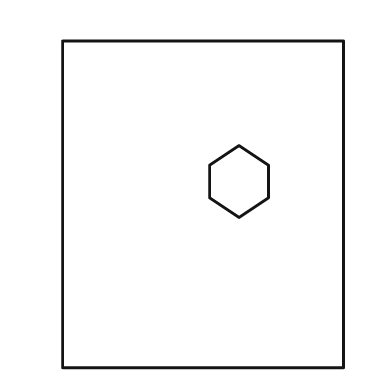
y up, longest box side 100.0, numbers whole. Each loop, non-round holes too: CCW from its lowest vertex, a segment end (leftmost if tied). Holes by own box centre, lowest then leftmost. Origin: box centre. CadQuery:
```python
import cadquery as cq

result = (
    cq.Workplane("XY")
    .moveTo(-43.0, -50.0)
    .lineTo(43.0, -50.0)
    .lineTo(43.0, 50.0)
    .lineTo(-43.0, 50.0)
    .close()
    .moveTo(11.0, -4.0)
    .lineTo(20.0, 2.0)
    .lineTo(20.0, 12.0)
    .lineTo(11.0, 18.0)
    .lineTo(2.0, 12.0)
    .lineTo(2.0, 2.0)
    .close()
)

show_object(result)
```